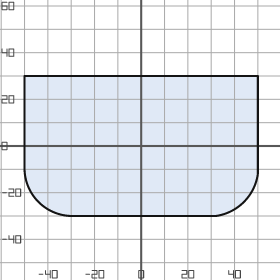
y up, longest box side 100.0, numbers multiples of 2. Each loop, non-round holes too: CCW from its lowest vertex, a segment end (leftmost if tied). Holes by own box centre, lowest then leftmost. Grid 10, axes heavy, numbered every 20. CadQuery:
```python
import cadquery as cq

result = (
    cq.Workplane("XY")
    .moveTo(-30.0, -30.0)
    .lineTo(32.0, -30.0)
    .threePointArc((44.0, -24.0), (50.0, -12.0))
    .lineTo(50.0, 30.0)
    .lineTo(-50.0, 30.0)
    .lineTo(-50.0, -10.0)
    .threePointArc((-44.0, -24.0), (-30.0, -30.0))
    .close()
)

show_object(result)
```